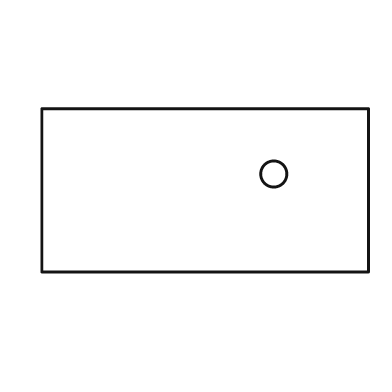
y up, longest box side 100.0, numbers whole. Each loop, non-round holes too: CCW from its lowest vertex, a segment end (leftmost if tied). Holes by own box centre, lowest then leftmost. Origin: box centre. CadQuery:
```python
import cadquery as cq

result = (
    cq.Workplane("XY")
    .moveTo(-50.0, -25.0)
    .lineTo(50.0, -25.0)
    .lineTo(50.0, 25.0)
    .lineTo(-50.0, 25.0)
    .close()
    .moveTo(21.0, 5.0)
    .circle(4.0)
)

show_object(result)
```